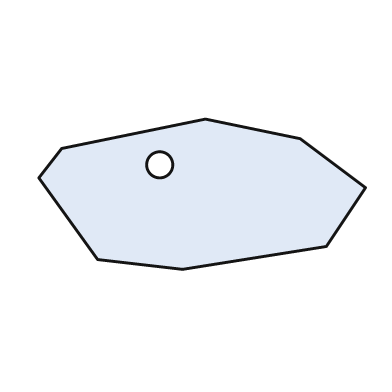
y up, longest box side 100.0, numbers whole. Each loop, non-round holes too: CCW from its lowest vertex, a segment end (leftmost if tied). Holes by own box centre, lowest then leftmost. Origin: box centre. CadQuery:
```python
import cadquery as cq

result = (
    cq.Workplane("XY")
    .moveTo(-6.0, -23.0)
    .lineTo(38.0, -16.0)
    .lineTo(50.0, 2.0)
    .lineTo(30.0, 17.0)
    .lineTo(1.0, 23.0)
    .lineTo(-43.0, 14.0)
    .lineTo(-50.0, 5.0)
    .lineTo(-32.0, -20.0)
    .close()
    .moveTo(-13.0, 9.0)
    .circle(4.0)
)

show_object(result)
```